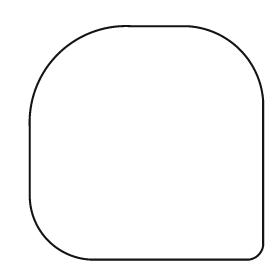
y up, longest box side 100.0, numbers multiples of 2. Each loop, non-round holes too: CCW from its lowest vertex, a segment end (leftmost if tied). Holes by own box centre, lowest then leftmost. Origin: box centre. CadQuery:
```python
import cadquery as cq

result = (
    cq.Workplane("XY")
    .moveTo(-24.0, -50.0)
    .lineTo(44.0, -50.0)
    .threePointArc((48.0, -48.0), (50.0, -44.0))
    .lineTo(50.0, 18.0)
    .threePointArc((40.0, 40.0), (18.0, 50.0))
    .lineTo(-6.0, 50.0)
    .threePointArc((-38.0, 38.0), (-50.0, 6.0))
    .lineTo(-50.0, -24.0)
    .threePointArc((-42.0, -42.0), (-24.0, -50.0))
    .close()
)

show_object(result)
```